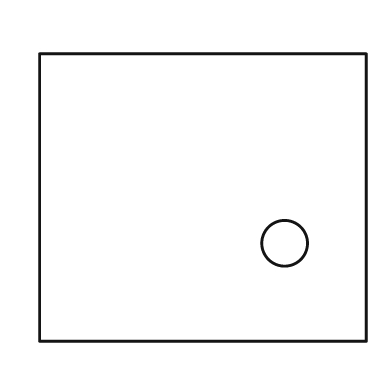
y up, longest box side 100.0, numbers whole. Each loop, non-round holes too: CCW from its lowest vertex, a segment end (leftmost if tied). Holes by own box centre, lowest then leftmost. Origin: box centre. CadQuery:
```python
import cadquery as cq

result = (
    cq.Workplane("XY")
    .moveTo(-50.0, -44.0)
    .lineTo(50.0, -44.0)
    .lineTo(50.0, 44.0)
    .lineTo(-50.0, 44.0)
    .close()
    .moveTo(25.0, -14.0)
    .circle(7.0)
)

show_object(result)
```